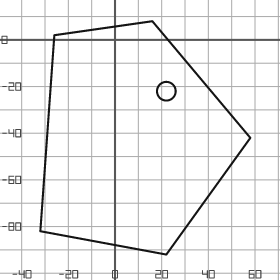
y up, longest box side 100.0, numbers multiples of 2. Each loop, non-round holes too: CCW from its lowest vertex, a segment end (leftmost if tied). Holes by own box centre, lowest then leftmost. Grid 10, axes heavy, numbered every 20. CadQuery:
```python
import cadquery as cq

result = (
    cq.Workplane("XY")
    .moveTo(22.0, -92.0)
    .lineTo(58.0, -42.0)
    .lineTo(16.0, 8.0)
    .lineTo(-26.0, 2.0)
    .lineTo(-32.0, -82.0)
    .close()
    .moveTo(22.0, -22.0)
    .circle(4.0)
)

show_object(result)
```